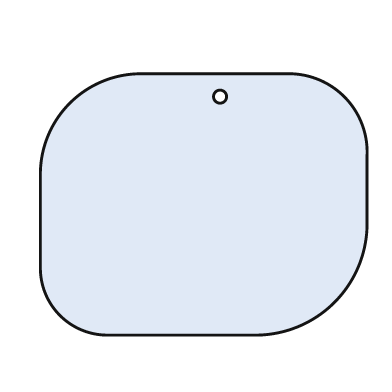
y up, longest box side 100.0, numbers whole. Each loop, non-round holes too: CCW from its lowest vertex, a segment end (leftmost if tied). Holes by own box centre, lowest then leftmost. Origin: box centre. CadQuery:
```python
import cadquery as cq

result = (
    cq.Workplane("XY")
    .moveTo(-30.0, -40.0)
    .lineTo(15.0, -40.0)
    .threePointArc((40.0, -30.0), (50.0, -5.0))
    .lineTo(50.0, 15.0)
    .threePointArc((43.0, 33.0), (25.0, 40.0))
    .lineTo(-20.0, 40.0)
    .threePointArc((-41.0, 31.0), (-50.0, 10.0))
    .lineTo(-50.0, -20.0)
    .threePointArc((-44.0, -34.0), (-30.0, -40.0))
    .close()
    .moveTo(5.0, 33.0)
    .circle(2.0)
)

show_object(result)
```